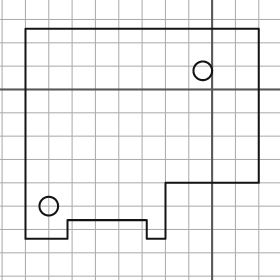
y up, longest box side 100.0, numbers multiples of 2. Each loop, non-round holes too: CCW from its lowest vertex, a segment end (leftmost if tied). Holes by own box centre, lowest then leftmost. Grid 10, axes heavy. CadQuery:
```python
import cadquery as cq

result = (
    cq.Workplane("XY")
    .moveTo(-80.0, -64.0)
    .lineTo(-62.0, -64.0)
    .lineTo(-62.0, -56.0)
    .lineTo(-28.0, -56.0)
    .lineTo(-28.0, -64.0)
    .lineTo(-20.0, -64.0)
    .lineTo(-20.0, -40.0)
    .lineTo(20.0, -40.0)
    .lineTo(20.0, 26.0)
    .lineTo(-80.0, 26.0)
    .close()
    .moveTo(-70.0, -50.0)
    .circle(4.0)
    .moveTo(-4.0, 8.0)
    .circle(4.0)
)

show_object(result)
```